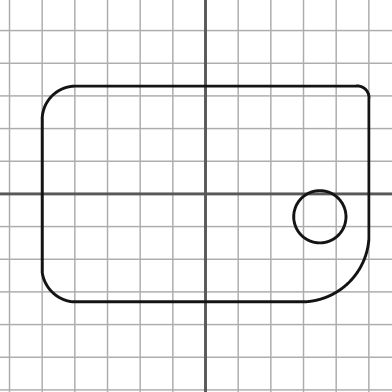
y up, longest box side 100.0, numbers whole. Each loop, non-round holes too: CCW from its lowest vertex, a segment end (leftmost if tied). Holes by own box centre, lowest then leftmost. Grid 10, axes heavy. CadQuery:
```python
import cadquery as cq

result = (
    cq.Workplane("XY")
    .moveTo(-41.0, -33.0)
    .lineTo(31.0, -33.0)
    .threePointArc((44.0, -27.0), (50.0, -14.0))
    .lineTo(50.0, 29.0)
    .threePointArc((49.0, 32.0), (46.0, 33.0))
    .lineTo(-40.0, 33.0)
    .threePointArc((-47.0, 30.0), (-50.0, 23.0))
    .lineTo(-50.0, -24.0)
    .threePointArc((-47.0, -30.0), (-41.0, -33.0))
    .close()
    .moveTo(35.0, -7.0)
    .circle(8.0)
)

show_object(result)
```